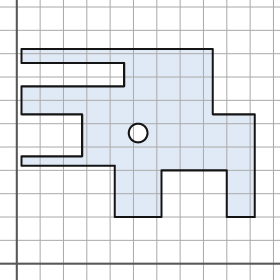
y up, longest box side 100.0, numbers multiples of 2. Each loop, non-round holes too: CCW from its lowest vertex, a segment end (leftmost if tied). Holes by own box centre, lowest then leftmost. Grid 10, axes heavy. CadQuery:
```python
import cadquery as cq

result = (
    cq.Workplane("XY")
    .moveTo(42.0, 20.0)
    .lineTo(62.0, 20.0)
    .lineTo(62.0, 40.0)
    .lineTo(90.0, 40.0)
    .lineTo(90.0, 20.0)
    .lineTo(102.0, 20.0)
    .lineTo(102.0, 64.0)
    .lineTo(84.0, 64.0)
    .lineTo(84.0, 92.0)
    .lineTo(2.0, 92.0)
    .lineTo(2.0, 86.0)
    .lineTo(46.0, 86.0)
    .lineTo(46.0, 76.0)
    .lineTo(2.0, 76.0)
    .lineTo(2.0, 64.0)
    .lineTo(28.0, 64.0)
    .lineTo(28.0, 46.0)
    .lineTo(2.0, 46.0)
    .lineTo(2.0, 42.0)
    .lineTo(42.0, 42.0)
    .close()
    .moveTo(52.0, 56.0)
    .circle(4.0)
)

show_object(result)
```